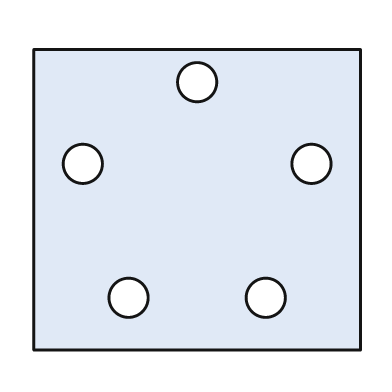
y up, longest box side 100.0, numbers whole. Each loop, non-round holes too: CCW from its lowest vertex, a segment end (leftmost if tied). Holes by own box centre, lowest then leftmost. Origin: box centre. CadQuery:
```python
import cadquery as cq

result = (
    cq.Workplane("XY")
    .moveTo(-50.0, -46.0)
    .lineTo(50.0, -46.0)
    .lineTo(50.0, 46.0)
    .lineTo(-50.0, 46.0)
    .close()
    .moveTo(-21.0, -30.0)
    .circle(6.0)
    .moveTo(21.0, -30.0)
    .circle(6.0)
    .moveTo(-35.0, 11.0)
    .circle(6.0)
    .moveTo(35.0, 11.0)
    .circle(6.0)
    .moveTo(0.0, 36.0)
    .circle(6.0)
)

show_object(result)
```